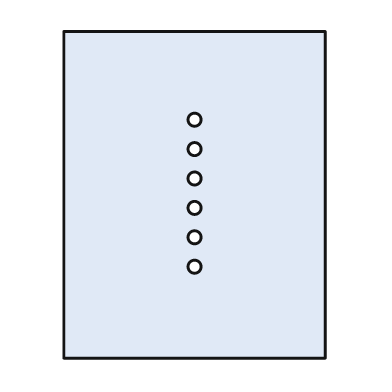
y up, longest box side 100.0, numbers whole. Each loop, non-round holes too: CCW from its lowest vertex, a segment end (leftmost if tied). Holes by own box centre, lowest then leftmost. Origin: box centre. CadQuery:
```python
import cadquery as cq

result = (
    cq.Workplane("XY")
    .moveTo(-40.0, -50.0)
    .lineTo(40.0, -50.0)
    .lineTo(40.0, 50.0)
    .lineTo(-40.0, 50.0)
    .close()
    .moveTo(0.0, -22.0)
    .circle(2.0)
    .moveTo(0.0, -13.0)
    .circle(2.0)
    .moveTo(0.0, -4.0)
    .circle(2.0)
    .moveTo(0.0, 5.0)
    .circle(2.0)
    .moveTo(0.0, 14.0)
    .circle(2.0)
    .moveTo(0.0, 23.0)
    .circle(2.0)
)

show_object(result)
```